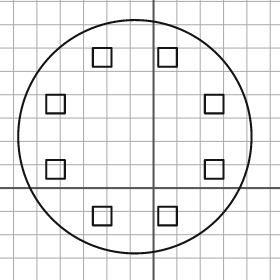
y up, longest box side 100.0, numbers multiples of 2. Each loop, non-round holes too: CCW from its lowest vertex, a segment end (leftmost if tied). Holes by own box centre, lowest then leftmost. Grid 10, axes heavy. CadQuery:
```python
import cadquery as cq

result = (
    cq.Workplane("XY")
    .moveTo(-8.0, 22.0)
    .circle(50.0)
    .moveTo(-26.0, -16.0)
    .lineTo(-18.0, -16.0)
    .lineTo(-18.0, -8.0)
    .lineTo(-26.0, -8.0)
    .close()
    .moveTo(2.0, -16.0)
    .lineTo(10.0, -16.0)
    .lineTo(10.0, -8.0)
    .lineTo(2.0, -8.0)
    .close()
    .moveTo(-46.0, 4.0)
    .lineTo(-38.0, 4.0)
    .lineTo(-38.0, 12.0)
    .lineTo(-46.0, 12.0)
    .close()
    .moveTo(22.0, 4.0)
    .lineTo(30.0, 4.0)
    .lineTo(30.0, 12.0)
    .lineTo(22.0, 12.0)
    .close()
    .moveTo(-46.0, 32.0)
    .lineTo(-38.0, 32.0)
    .lineTo(-38.0, 40.0)
    .lineTo(-46.0, 40.0)
    .close()
    .moveTo(22.0, 32.0)
    .lineTo(30.0, 32.0)
    .lineTo(30.0, 40.0)
    .lineTo(22.0, 40.0)
    .close()
    .moveTo(-26.0, 52.0)
    .lineTo(-18.0, 52.0)
    .lineTo(-18.0, 60.0)
    .lineTo(-26.0, 60.0)
    .close()
    .moveTo(2.0, 52.0)
    .lineTo(10.0, 52.0)
    .lineTo(10.0, 60.0)
    .lineTo(2.0, 60.0)
    .close()
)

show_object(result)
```